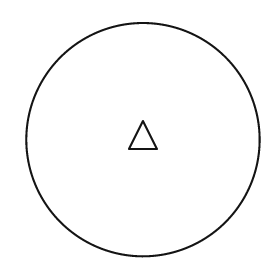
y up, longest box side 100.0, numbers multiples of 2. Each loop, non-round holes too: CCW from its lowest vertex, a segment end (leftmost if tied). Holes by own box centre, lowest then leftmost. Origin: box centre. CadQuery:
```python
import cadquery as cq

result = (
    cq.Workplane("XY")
    .moveTo(0.0, 0.0)
    .circle(50.0)
    .moveTo(-6.0, -4.0)
    .lineTo(6.0, -4.0)
    .lineTo(0.0, 8.0)
    .close()
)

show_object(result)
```